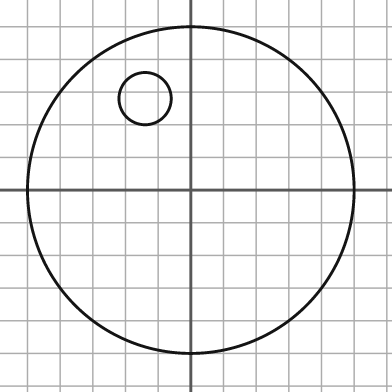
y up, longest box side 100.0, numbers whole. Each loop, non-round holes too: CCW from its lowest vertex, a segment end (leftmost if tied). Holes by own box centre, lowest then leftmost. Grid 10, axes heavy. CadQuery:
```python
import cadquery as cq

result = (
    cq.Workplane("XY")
    .moveTo(0.0, 0.0)
    .circle(50.0)
    .moveTo(-14.0, 28.0)
    .circle(8.0)
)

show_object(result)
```